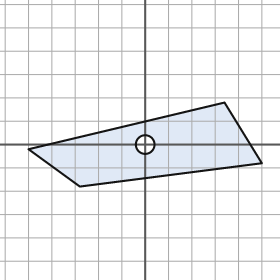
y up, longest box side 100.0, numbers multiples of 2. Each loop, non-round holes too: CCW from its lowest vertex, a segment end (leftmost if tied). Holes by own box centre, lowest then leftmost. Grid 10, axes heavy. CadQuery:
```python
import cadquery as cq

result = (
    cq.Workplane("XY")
    .moveTo(-28.0, -18.0)
    .lineTo(50.0, -8.0)
    .lineTo(34.0, 18.0)
    .lineTo(-50.0, -2.0)
    .close()
    .moveTo(0.0, 0.0)
    .circle(4.0)
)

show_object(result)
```